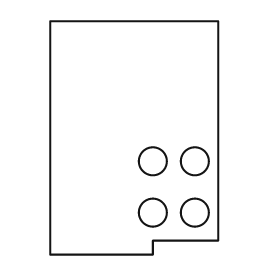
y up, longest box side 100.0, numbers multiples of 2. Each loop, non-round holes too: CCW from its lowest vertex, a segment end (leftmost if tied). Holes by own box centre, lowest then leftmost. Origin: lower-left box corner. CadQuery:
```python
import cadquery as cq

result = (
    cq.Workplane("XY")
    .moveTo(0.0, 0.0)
    .lineTo(44.0, 0.0)
    .lineTo(44.0, 6.0)
    .lineTo(72.0, 6.0)
    .lineTo(72.0, 100.0)
    .lineTo(0.0, 100.0)
    .close()
    .moveTo(44.0, 18.0)
    .circle(6.0)
    .moveTo(62.0, 18.0)
    .circle(6.0)
    .moveTo(44.0, 40.0)
    .circle(6.0)
    .moveTo(62.0, 40.0)
    .circle(6.0)
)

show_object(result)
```